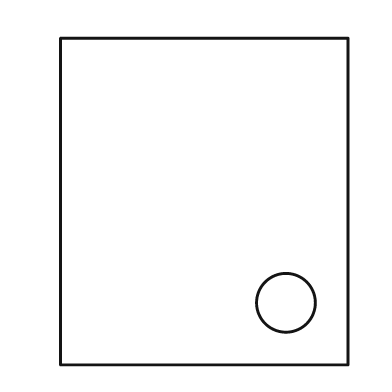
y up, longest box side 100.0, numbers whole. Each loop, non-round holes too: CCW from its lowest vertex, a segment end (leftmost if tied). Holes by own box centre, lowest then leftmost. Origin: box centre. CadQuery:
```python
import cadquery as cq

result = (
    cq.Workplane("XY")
    .moveTo(-44.0, -50.0)
    .lineTo(44.0, -50.0)
    .lineTo(44.0, 50.0)
    .lineTo(-44.0, 50.0)
    .close()
    .moveTo(25.0, -31.0)
    .circle(9.0)
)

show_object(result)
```